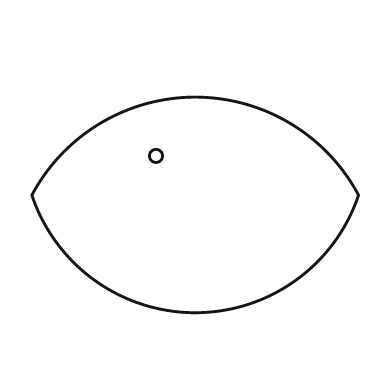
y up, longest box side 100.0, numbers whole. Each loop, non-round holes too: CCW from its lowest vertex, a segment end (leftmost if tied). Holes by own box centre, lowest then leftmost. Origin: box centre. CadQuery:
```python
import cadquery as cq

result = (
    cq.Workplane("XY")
    .moveTo(-50.0, 3.0)
    .threePointArc((0.0, -33.0), (50.0, 3.0))
    .threePointArc((0.0, 33.0), (-50.0, 3.0))
    .close()
    .moveTo(-12.0, 15.0)
    .circle(2.0)
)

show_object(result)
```